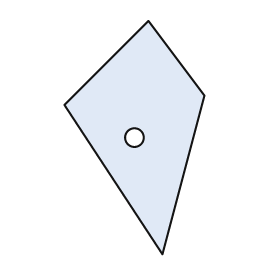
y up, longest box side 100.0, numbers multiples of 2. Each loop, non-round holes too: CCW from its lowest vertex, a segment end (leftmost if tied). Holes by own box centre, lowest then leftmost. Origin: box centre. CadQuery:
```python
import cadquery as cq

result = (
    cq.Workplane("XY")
    .moveTo(12.0, -50.0)
    .lineTo(30.0, 18.0)
    .lineTo(6.0, 50.0)
    .lineTo(-30.0, 14.0)
    .close()
    .moveTo(0.0, 0.0)
    .circle(4.0)
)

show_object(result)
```